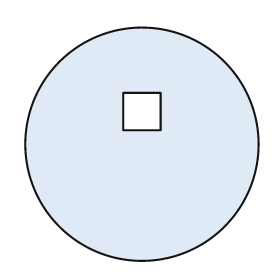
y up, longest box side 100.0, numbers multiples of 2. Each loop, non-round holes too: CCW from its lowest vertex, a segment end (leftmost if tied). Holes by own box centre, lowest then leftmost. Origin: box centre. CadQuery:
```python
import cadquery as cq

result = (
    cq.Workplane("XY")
    .moveTo(0.0, 0.0)
    .circle(50.0)
    .moveTo(-8.0, 6.0)
    .lineTo(8.0, 6.0)
    .lineTo(8.0, 22.0)
    .lineTo(-8.0, 22.0)
    .close()
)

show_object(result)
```